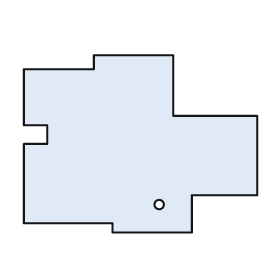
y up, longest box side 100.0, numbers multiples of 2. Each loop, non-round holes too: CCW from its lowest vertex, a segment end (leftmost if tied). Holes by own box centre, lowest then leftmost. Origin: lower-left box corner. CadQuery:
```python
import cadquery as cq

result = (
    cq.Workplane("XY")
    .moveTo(38.0, 0.0)
    .lineTo(72.0, 0.0)
    .lineTo(72.0, 16.0)
    .lineTo(100.0, 16.0)
    .lineTo(100.0, 50.0)
    .lineTo(64.0, 50.0)
    .lineTo(64.0, 76.0)
    .lineTo(30.0, 76.0)
    .lineTo(30.0, 70.0)
    .lineTo(0.0, 70.0)
    .lineTo(0.0, 46.0)
    .lineTo(10.0, 46.0)
    .lineTo(10.0, 38.0)
    .lineTo(0.0, 38.0)
    .lineTo(0.0, 4.0)
    .lineTo(38.0, 4.0)
    .close()
    .moveTo(58.0, 12.0)
    .circle(2.0)
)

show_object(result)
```